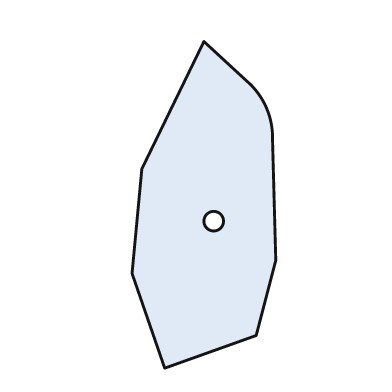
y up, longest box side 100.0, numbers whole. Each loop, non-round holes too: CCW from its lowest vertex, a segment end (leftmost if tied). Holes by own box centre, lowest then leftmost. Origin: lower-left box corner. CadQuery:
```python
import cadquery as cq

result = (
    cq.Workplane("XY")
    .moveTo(10.0, 0.0)
    .lineTo(38.0, 10.0)
    .lineTo(44.0, 33.0)
    .lineTo(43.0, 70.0)
    .threePointArc((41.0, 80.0), (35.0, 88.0))
    .lineTo(22.0, 100.0)
    .lineTo(3.0, 61.0)
    .lineTo(0.0, 29.0)
    .close()
    .moveTo(25.0, 45.0)
    .circle(3.0)
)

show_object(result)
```